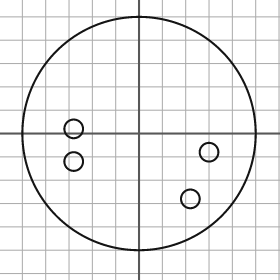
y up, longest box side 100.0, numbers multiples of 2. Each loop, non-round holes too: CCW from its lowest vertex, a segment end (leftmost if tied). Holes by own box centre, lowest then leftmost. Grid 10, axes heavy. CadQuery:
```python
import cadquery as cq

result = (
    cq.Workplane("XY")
    .moveTo(0.0, 0.0)
    .circle(50.0)
    .moveTo(22.0, -28.0)
    .circle(4.0)
    .moveTo(-28.0, -12.0)
    .circle(4.0)
    .moveTo(30.0, -8.0)
    .circle(4.0)
    .moveTo(-28.0, 2.0)
    .circle(4.0)
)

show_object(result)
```